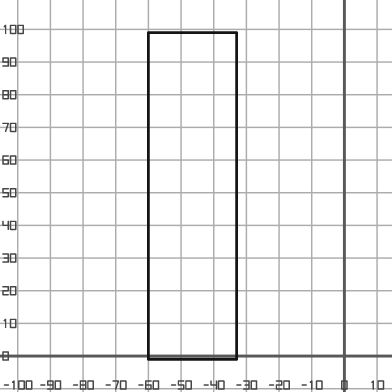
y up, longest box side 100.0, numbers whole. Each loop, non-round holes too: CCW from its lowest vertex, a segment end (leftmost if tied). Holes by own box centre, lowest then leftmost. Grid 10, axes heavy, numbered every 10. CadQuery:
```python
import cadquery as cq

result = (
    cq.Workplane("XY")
    .moveTo(-60.0, -1.0)
    .lineTo(-33.0, -1.0)
    .lineTo(-33.0, 99.0)
    .lineTo(-60.0, 99.0)
    .close()
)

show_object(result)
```